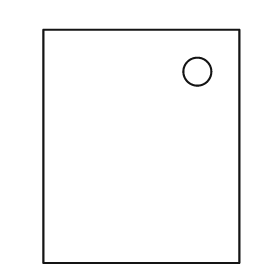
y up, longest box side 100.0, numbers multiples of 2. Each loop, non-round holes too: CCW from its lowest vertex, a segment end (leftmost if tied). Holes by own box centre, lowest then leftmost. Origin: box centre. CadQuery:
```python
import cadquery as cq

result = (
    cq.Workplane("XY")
    .moveTo(-42.0, -50.0)
    .lineTo(42.0, -50.0)
    .lineTo(42.0, 50.0)
    .lineTo(-42.0, 50.0)
    .close()
    .moveTo(24.0, 32.0)
    .circle(6.0)
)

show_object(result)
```